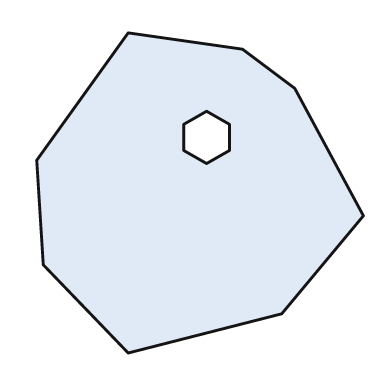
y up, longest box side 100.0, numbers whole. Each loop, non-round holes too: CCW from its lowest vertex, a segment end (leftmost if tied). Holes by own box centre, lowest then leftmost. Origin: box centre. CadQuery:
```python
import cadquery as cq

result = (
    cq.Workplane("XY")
    .moveTo(-22.0, -49.0)
    .lineTo(25.0, -37.0)
    .lineTo(50.0, -7.0)
    .lineTo(29.0, 32.0)
    .lineTo(13.0, 44.0)
    .lineTo(-22.0, 49.0)
    .lineTo(-50.0, 10.0)
    .lineTo(-48.0, -22.0)
    .close()
    .moveTo(2.0, 9.0)
    .lineTo(9.0, 13.0)
    .lineTo(9.0, 21.0)
    .lineTo(2.0, 25.0)
    .lineTo(-5.0, 21.0)
    .lineTo(-5.0, 13.0)
    .close()
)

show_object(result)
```